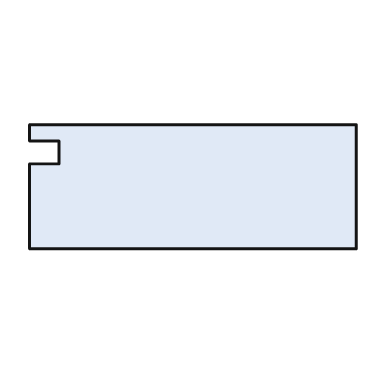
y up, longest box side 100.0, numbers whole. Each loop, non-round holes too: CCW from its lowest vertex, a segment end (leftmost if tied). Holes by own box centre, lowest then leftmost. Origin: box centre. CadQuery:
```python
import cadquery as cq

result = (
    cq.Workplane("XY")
    .moveTo(-50.0, -19.0)
    .lineTo(50.0, -19.0)
    .lineTo(50.0, 19.0)
    .lineTo(-50.0, 19.0)
    .lineTo(-50.0, 14.0)
    .lineTo(-41.0, 14.0)
    .lineTo(-41.0, 7.0)
    .lineTo(-50.0, 7.0)
    .close()
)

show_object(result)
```